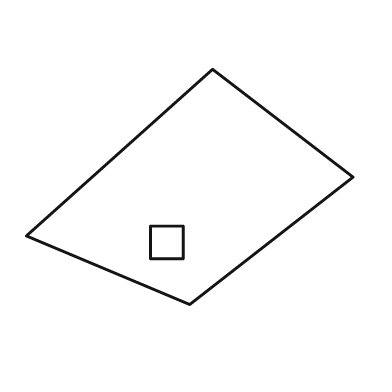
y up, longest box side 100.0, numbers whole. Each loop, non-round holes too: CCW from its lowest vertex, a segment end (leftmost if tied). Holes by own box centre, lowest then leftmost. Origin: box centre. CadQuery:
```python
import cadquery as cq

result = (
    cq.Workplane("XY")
    .moveTo(0.0, -36.0)
    .lineTo(50.0, 3.0)
    .lineTo(7.0, 36.0)
    .lineTo(-50.0, -15.0)
    .close()
    .moveTo(-12.0, -22.0)
    .lineTo(-2.0, -22.0)
    .lineTo(-2.0, -12.0)
    .lineTo(-12.0, -12.0)
    .close()
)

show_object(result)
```